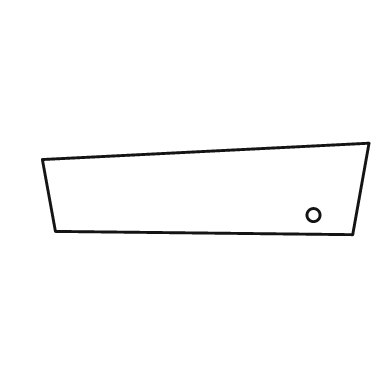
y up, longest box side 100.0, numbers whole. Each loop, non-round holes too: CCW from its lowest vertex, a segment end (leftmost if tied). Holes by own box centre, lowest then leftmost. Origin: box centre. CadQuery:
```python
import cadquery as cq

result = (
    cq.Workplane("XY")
    .moveTo(45.0, -14.0)
    .lineTo(50.0, 14.0)
    .lineTo(-50.0, 9.0)
    .lineTo(-46.0, -13.0)
    .close()
    .moveTo(33.0, -8.0)
    .circle(2.0)
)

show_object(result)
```